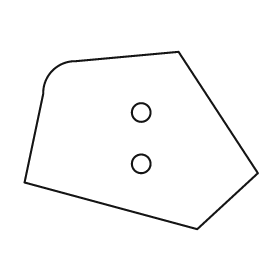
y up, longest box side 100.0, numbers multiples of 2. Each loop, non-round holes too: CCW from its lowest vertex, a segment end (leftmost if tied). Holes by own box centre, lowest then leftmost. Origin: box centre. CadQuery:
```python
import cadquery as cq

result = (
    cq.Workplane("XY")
    .moveTo(24.0, -38.0)
    .lineTo(50.0, -14.0)
    .lineTo(16.0, 38.0)
    .lineTo(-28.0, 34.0)
    .threePointArc((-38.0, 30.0), (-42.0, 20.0))
    .lineTo(-50.0, -18.0)
    .close()
    .moveTo(0.0, -10.0)
    .circle(4.0)
    .moveTo(0.0, 12.0)
    .circle(4.0)
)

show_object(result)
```